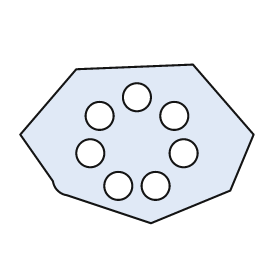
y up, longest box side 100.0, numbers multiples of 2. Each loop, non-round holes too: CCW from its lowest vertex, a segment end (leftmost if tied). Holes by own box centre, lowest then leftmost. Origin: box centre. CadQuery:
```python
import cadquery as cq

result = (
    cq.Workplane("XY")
    .moveTo(6.0, -34.0)
    .lineTo(40.0, -20.0)
    .lineTo(50.0, 4.0)
    .lineTo(24.0, 34.0)
    .lineTo(-26.0, 32.0)
    .lineTo(-50.0, 4.0)
    .lineTo(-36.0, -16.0)
    .threePointArc((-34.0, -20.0), (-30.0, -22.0))
    .close()
    .moveTo(-8.0, -18.0)
    .circle(6.0)
    .moveTo(8.0, -18.0)
    .circle(6.0)
    .moveTo(-20.0, -4.0)
    .circle(6.0)
    .moveTo(20.0, -4.0)
    .circle(6.0)
    .moveTo(-16.0, 12.0)
    .circle(6.0)
    .moveTo(16.0, 12.0)
    .circle(6.0)
    .moveTo(0.0, 20.0)
    .circle(6.0)
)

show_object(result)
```